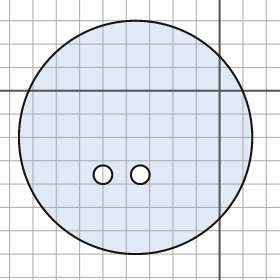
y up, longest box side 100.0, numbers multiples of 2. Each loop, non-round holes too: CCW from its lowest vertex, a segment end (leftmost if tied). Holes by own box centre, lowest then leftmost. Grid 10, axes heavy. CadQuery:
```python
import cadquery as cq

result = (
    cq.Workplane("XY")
    .moveTo(-36.0, -20.0)
    .circle(50.0)
    .moveTo(-50.0, -36.0)
    .circle(4.0)
    .moveTo(-34.0, -36.0)
    .circle(4.0)
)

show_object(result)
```